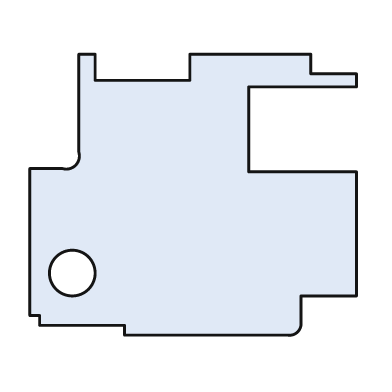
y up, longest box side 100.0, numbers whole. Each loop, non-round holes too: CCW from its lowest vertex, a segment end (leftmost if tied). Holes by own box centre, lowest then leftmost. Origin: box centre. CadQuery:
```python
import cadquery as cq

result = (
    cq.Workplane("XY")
    .moveTo(-21.0, -43.0)
    .lineTo(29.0, -43.0)
    .threePointArc((32.0, -42.0), (33.0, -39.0))
    .lineTo(33.0, -31.0)
    .lineTo(50.0, -31.0)
    .lineTo(50.0, 7.0)
    .lineTo(17.0, 7.0)
    .lineTo(17.0, 33.0)
    .lineTo(50.0, 33.0)
    .lineTo(50.0, 37.0)
    .lineTo(36.0, 37.0)
    .lineTo(36.0, 43.0)
    .lineTo(-1.0, 43.0)
    .lineTo(-1.0, 35.0)
    .lineTo(-30.0, 35.0)
    .lineTo(-30.0, 43.0)
    .lineTo(-35.0, 43.0)
    .lineTo(-35.0, 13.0)
    .threePointArc((-36.0, 9.0), (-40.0, 8.0))
    .lineTo(-50.0, 8.0)
    .lineTo(-50.0, -37.0)
    .lineTo(-47.0, -37.0)
    .lineTo(-47.0, -40.0)
    .lineTo(-21.0, -40.0)
    .close()
    .moveTo(-37.0, -24.0)
    .circle(7.0)
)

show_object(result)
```